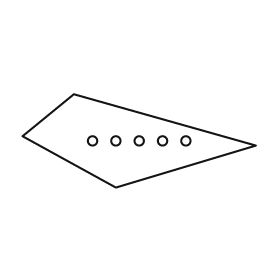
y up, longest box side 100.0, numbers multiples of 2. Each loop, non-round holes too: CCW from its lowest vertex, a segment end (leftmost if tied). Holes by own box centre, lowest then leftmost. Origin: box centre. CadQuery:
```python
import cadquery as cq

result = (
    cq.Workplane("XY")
    .moveTo(-10.0, -20.0)
    .lineTo(50.0, -2.0)
    .lineTo(-28.0, 20.0)
    .lineTo(-50.0, 2.0)
    .close()
    .moveTo(-20.0, 0.0)
    .circle(2.0)
    .moveTo(-10.0, 0.0)
    .circle(2.0)
    .moveTo(0.0, 0.0)
    .circle(2.0)
    .moveTo(10.0, 0.0)
    .circle(2.0)
    .moveTo(20.0, 0.0)
    .circle(2.0)
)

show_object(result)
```